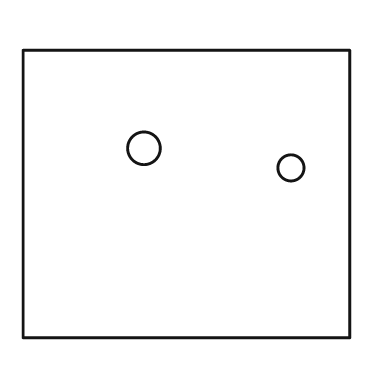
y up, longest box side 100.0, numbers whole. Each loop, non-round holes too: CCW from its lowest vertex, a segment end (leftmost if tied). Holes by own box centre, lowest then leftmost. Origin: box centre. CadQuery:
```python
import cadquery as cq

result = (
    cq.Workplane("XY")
    .moveTo(-50.0, -44.0)
    .lineTo(50.0, -44.0)
    .lineTo(50.0, 44.0)
    .lineTo(-50.0, 44.0)
    .close()
    .moveTo(32.0, 8.0)
    .circle(4.0)
    .moveTo(-13.0, 14.0)
    .circle(5.0)
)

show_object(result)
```